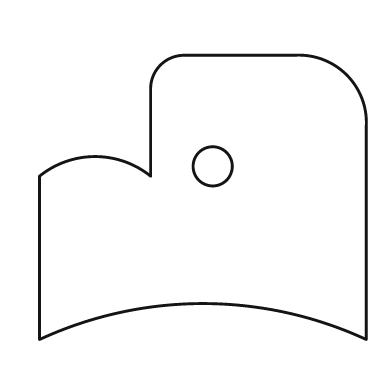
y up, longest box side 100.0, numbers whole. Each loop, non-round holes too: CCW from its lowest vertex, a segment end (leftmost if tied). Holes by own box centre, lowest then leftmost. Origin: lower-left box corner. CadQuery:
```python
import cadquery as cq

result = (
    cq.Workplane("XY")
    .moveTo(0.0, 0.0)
    .threePointArc((50.0, 11.0), (100.0, 0.0))
    .lineTo(100.0, 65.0)
    .threePointArc((94.0, 81.0), (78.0, 87.0))
    .lineTo(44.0, 87.0)
    .threePointArc((37.0, 84.0), (34.0, 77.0))
    .lineTo(34.0, 50.0)
    .threePointArc((17.0, 56.0), (0.0, 50.0))
    .close()
    .moveTo(53.0, 53.0)
    .circle(6.0)
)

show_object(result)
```